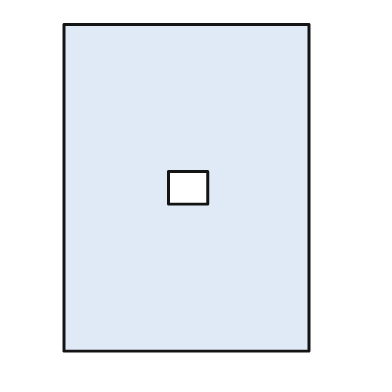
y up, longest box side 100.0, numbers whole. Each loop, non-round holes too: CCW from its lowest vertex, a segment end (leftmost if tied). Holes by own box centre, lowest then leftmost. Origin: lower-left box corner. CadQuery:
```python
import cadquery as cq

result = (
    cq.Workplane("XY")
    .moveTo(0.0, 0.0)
    .lineTo(75.0, 0.0)
    .lineTo(75.0, 100.0)
    .lineTo(0.0, 100.0)
    .close()
    .moveTo(32.0, 45.0)
    .lineTo(44.0, 45.0)
    .lineTo(44.0, 55.0)
    .lineTo(32.0, 55.0)
    .close()
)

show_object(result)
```